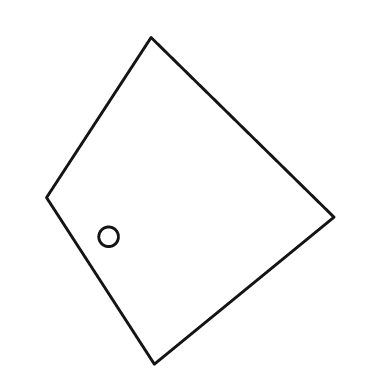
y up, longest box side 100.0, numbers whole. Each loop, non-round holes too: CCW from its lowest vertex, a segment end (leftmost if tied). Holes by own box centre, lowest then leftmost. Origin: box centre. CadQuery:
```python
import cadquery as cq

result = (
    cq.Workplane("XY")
    .moveTo(-11.0, -50.0)
    .lineTo(44.0, -5.0)
    .lineTo(-12.0, 50.0)
    .lineTo(-44.0, 1.0)
    .close()
    .moveTo(-25.0, -11.0)
    .circle(3.0)
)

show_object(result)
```